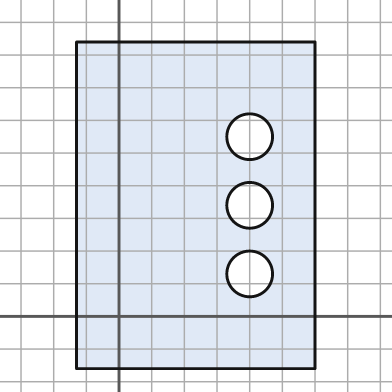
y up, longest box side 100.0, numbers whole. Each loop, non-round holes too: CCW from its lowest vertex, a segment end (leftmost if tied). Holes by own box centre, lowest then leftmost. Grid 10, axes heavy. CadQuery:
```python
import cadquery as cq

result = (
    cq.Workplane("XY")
    .moveTo(-13.0, -16.0)
    .lineTo(60.0, -16.0)
    .lineTo(60.0, 84.0)
    .lineTo(-13.0, 84.0)
    .close()
    .moveTo(40.0, 13.0)
    .circle(7.0)
    .moveTo(40.0, 34.0)
    .circle(7.0)
    .moveTo(40.0, 55.0)
    .circle(7.0)
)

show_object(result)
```